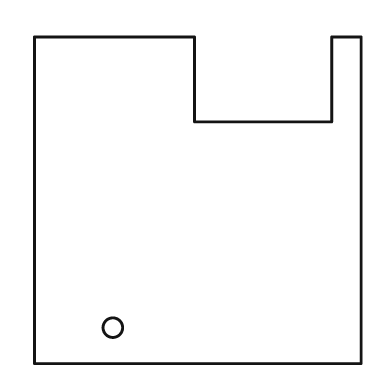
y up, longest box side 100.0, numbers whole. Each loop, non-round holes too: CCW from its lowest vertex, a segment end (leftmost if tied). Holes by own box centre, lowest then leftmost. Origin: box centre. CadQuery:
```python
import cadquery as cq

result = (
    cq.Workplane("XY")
    .moveTo(-50.0, -50.0)
    .lineTo(50.0, -50.0)
    .lineTo(50.0, 50.0)
    .lineTo(41.0, 50.0)
    .lineTo(41.0, 24.0)
    .lineTo(-1.0, 24.0)
    .lineTo(-1.0, 50.0)
    .lineTo(-50.0, 50.0)
    .close()
    .moveTo(-26.0, -39.0)
    .circle(3.0)
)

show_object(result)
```